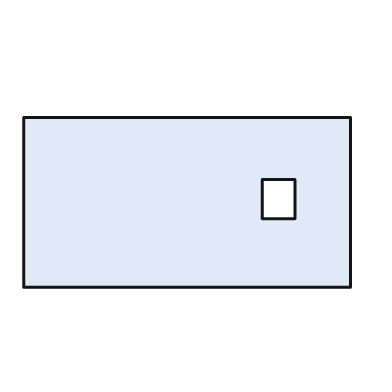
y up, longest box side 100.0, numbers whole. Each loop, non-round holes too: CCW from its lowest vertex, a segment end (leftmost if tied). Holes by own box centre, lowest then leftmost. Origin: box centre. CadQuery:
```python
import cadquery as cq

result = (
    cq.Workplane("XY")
    .moveTo(-50.0, -26.0)
    .lineTo(50.0, -26.0)
    .lineTo(50.0, 26.0)
    .lineTo(-50.0, 26.0)
    .close()
    .moveTo(23.0, -5.0)
    .lineTo(33.0, -5.0)
    .lineTo(33.0, 7.0)
    .lineTo(23.0, 7.0)
    .close()
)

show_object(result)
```